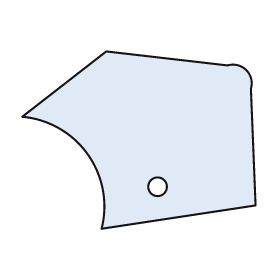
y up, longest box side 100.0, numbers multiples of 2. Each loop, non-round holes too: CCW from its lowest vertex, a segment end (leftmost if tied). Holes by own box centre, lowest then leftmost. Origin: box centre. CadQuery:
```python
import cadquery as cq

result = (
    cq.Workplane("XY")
    .moveTo(-16.0, -38.0)
    .lineTo(50.0, -28.0)
    .lineTo(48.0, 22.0)
    .threePointArc((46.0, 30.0), (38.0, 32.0))
    .lineTo(-14.0, 38.0)
    .lineTo(-50.0, 10.0)
    .threePointArc((-22.0, -6.0), (-16.0, -38.0))
    .close()
    .moveTo(8.0, -20.0)
    .circle(4.0)
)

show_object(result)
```